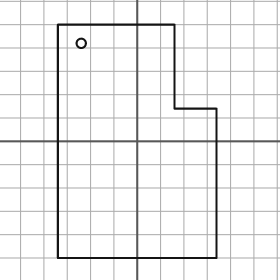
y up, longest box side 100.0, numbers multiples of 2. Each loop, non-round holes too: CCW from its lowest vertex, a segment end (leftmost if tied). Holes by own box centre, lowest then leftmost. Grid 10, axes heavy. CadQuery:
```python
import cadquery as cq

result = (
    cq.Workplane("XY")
    .moveTo(-34.0, -50.0)
    .lineTo(34.0, -50.0)
    .lineTo(34.0, 14.0)
    .lineTo(16.0, 14.0)
    .lineTo(16.0, 50.0)
    .lineTo(-34.0, 50.0)
    .close()
    .moveTo(-24.0, 42.0)
    .circle(2.0)
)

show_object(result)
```